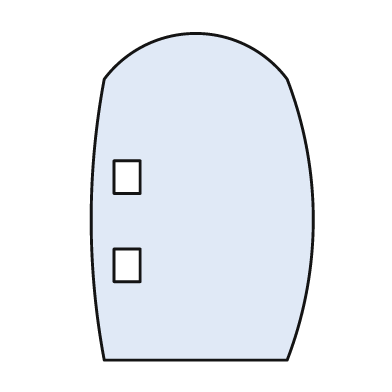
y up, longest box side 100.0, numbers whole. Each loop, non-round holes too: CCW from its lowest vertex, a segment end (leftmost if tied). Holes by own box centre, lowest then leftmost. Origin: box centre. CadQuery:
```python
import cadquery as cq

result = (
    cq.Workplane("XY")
    .moveTo(-30.0, -50.0)
    .lineTo(26.0, -50.0)
    .threePointArc((34.0, -7.0), (26.0, 36.0))
    .threePointArc((-2.0, 50.0), (-30.0, 36.0))
    .threePointArc((-34.0, -7.0), (-30.0, -50.0))
    .close()
    .moveTo(-27.0, -26.0)
    .lineTo(-19.0, -26.0)
    .lineTo(-19.0, -16.0)
    .lineTo(-27.0, -16.0)
    .close()
    .moveTo(-27.0, 1.0)
    .lineTo(-19.0, 1.0)
    .lineTo(-19.0, 11.0)
    .lineTo(-27.0, 11.0)
    .close()
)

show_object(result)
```